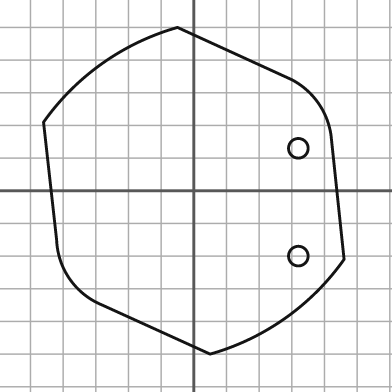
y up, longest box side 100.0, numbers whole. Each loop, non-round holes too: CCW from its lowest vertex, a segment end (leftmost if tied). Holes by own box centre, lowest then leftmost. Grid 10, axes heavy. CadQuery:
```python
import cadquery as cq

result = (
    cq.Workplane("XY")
    .moveTo(5.0, -50.0)
    .threePointArc((28.0, -39.0), (46.0, -21.0))
    .lineTo(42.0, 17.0)
    .threePointArc((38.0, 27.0), (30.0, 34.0))
    .lineTo(-5.0, 50.0)
    .threePointArc((-28.0, 39.0), (-46.0, 21.0))
    .lineTo(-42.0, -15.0)
    .threePointArc((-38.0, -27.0), (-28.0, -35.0))
    .close()
    .moveTo(32.0, -20.0)
    .circle(3.0)
    .moveTo(32.0, 13.0)
    .circle(3.0)
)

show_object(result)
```